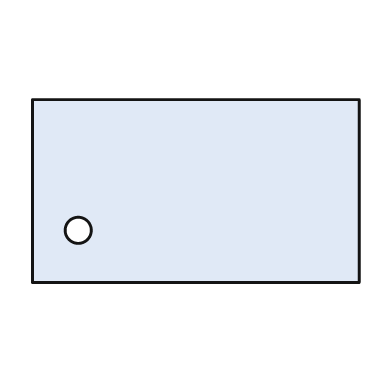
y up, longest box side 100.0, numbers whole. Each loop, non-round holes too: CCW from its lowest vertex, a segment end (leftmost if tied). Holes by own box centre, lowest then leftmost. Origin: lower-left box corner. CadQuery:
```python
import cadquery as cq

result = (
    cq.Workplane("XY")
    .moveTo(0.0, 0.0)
    .lineTo(100.0, 0.0)
    .lineTo(100.0, 56.0)
    .lineTo(0.0, 56.0)
    .close()
    .moveTo(14.0, 16.0)
    .circle(4.0)
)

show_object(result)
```